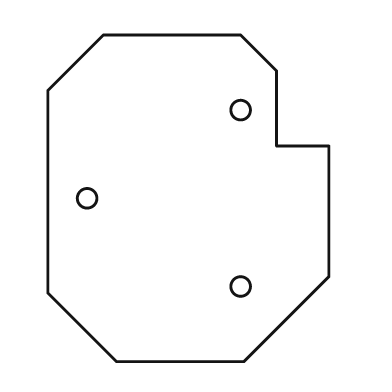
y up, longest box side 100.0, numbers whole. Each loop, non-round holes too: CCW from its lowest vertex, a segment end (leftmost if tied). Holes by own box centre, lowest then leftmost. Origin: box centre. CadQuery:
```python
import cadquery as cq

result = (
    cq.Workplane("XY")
    .moveTo(-22.0, -50.0)
    .lineTo(17.0, -50.0)
    .lineTo(43.0, -24.0)
    .lineTo(43.0, 16.0)
    .lineTo(27.0, 16.0)
    .lineTo(27.0, 39.0)
    .lineTo(16.0, 50.0)
    .lineTo(-26.0, 50.0)
    .lineTo(-43.0, 33.0)
    .lineTo(-43.0, -29.0)
    .close()
    .moveTo(16.0, -27.0)
    .circle(3.0)
    .moveTo(-31.0, 0.0)
    .circle(3.0)
    .moveTo(16.0, 27.0)
    .circle(3.0)
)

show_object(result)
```